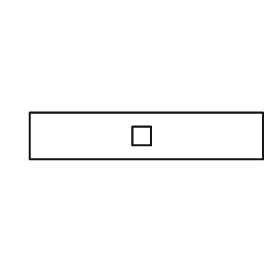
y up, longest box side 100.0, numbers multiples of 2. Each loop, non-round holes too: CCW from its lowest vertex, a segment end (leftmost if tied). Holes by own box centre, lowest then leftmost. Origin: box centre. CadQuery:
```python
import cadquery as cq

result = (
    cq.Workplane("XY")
    .moveTo(-50.0, -10.0)
    .lineTo(50.0, -10.0)
    .lineTo(50.0, 10.0)
    .lineTo(-50.0, 10.0)
    .close()
    .moveTo(-6.0, -4.0)
    .lineTo(2.0, -4.0)
    .lineTo(2.0, 4.0)
    .lineTo(-6.0, 4.0)
    .close()
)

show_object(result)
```